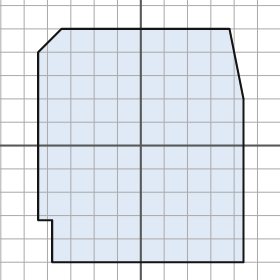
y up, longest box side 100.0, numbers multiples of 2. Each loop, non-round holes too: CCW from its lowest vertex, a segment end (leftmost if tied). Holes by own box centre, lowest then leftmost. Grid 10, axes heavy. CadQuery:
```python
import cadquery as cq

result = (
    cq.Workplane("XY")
    .moveTo(-38.0, -50.0)
    .lineTo(44.0, -50.0)
    .lineTo(44.0, 20.0)
    .lineTo(38.0, 50.0)
    .lineTo(-34.0, 50.0)
    .lineTo(-44.0, 40.0)
    .lineTo(-44.0, -32.0)
    .lineTo(-38.0, -32.0)
    .close()
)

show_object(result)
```